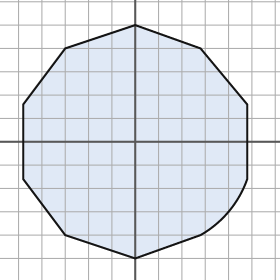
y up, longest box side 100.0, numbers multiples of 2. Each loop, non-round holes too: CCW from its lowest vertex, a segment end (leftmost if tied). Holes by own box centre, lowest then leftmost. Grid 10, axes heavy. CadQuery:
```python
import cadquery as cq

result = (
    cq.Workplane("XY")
    .moveTo(0.0, -50.0)
    .lineTo(28.0, -40.0)
    .threePointArc((40.0, -30.0), (48.0, -16.0))
    .lineTo(48.0, 16.0)
    .lineTo(28.0, 40.0)
    .lineTo(0.0, 50.0)
    .lineTo(-30.0, 40.0)
    .lineTo(-48.0, 16.0)
    .lineTo(-48.0, -16.0)
    .lineTo(-30.0, -40.0)
    .close()
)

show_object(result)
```